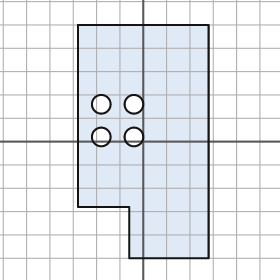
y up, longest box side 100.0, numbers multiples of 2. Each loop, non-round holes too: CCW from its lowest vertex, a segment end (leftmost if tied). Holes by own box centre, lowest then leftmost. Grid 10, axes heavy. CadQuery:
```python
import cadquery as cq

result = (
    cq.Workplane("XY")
    .moveTo(-6.0, -50.0)
    .lineTo(28.0, -50.0)
    .lineTo(28.0, 50.0)
    .lineTo(-28.0, 50.0)
    .lineTo(-28.0, -28.0)
    .lineTo(-6.0, -28.0)
    .close()
    .moveTo(-18.0, 2.0)
    .circle(4.0)
    .moveTo(-4.0, 2.0)
    .circle(4.0)
    .moveTo(-18.0, 16.0)
    .circle(4.0)
    .moveTo(-4.0, 16.0)
    .circle(4.0)
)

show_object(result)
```